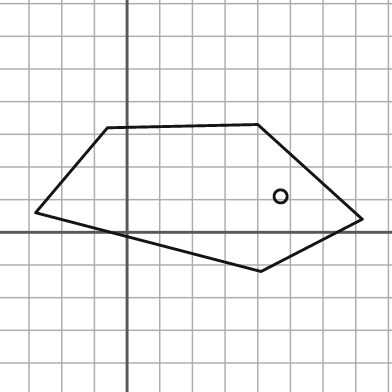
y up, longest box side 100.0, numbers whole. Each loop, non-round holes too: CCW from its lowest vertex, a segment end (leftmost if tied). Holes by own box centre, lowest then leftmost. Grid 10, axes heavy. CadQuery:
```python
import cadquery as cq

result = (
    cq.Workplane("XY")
    .moveTo(41.0, -12.0)
    .lineTo(72.0, 4.0)
    .lineTo(40.0, 33.0)
    .lineTo(-6.0, 32.0)
    .lineTo(-28.0, 6.0)
    .close()
    .moveTo(47.0, 11.0)
    .circle(2.0)
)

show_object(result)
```